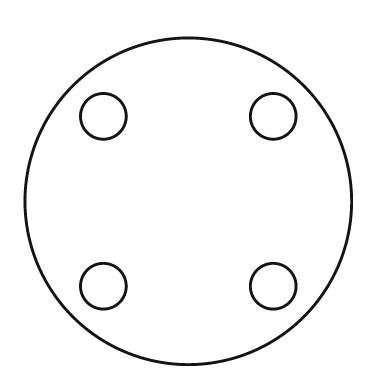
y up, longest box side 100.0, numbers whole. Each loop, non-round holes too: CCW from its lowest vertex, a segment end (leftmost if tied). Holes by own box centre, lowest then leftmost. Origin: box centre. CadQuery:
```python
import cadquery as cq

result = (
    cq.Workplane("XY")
    .moveTo(0.0, 0.0)
    .circle(50.0)
    .moveTo(-26.0, -26.0)
    .circle(7.0)
    .moveTo(26.0, -26.0)
    .circle(7.0)
    .moveTo(-26.0, 26.0)
    .circle(7.0)
    .moveTo(26.0, 26.0)
    .circle(7.0)
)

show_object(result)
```